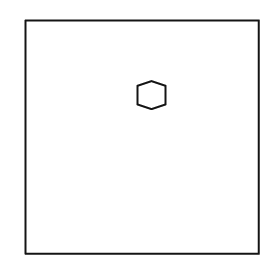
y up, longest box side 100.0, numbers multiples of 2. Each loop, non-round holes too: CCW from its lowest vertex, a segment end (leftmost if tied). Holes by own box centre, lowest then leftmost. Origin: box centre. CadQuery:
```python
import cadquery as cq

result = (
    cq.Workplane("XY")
    .moveTo(-50.0, -50.0)
    .lineTo(50.0, -50.0)
    .lineTo(50.0, 50.0)
    .lineTo(-50.0, 50.0)
    .close()
    .moveTo(4.0, 12.0)
    .lineTo(10.0, 14.0)
    .lineTo(10.0, 22.0)
    .lineTo(4.0, 24.0)
    .lineTo(-2.0, 22.0)
    .lineTo(-2.0, 14.0)
    .close()
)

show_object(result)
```